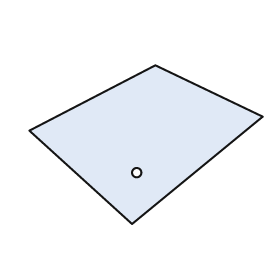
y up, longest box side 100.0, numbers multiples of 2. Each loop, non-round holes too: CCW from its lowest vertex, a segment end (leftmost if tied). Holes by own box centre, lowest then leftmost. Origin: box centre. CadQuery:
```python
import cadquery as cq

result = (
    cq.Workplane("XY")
    .moveTo(-6.0, -34.0)
    .lineTo(50.0, 12.0)
    .lineTo(4.0, 34.0)
    .lineTo(-50.0, 6.0)
    .close()
    .moveTo(-4.0, -12.0)
    .circle(2.0)
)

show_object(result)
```